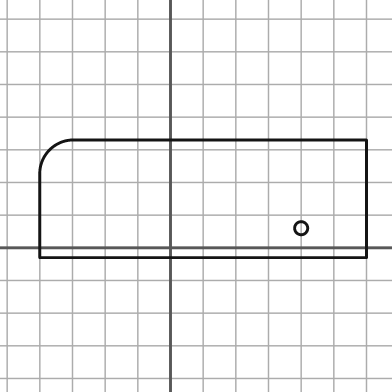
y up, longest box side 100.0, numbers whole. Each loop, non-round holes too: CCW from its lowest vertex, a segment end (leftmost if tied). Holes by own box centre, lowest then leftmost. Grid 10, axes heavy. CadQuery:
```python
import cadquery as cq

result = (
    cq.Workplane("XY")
    .moveTo(-40.0, -3.0)
    .lineTo(60.0, -3.0)
    .lineTo(60.0, 33.0)
    .lineTo(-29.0, 33.0)
    .threePointArc((-37.0, 30.0), (-40.0, 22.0))
    .close()
    .moveTo(40.0, 6.0)
    .circle(2.0)
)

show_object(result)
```